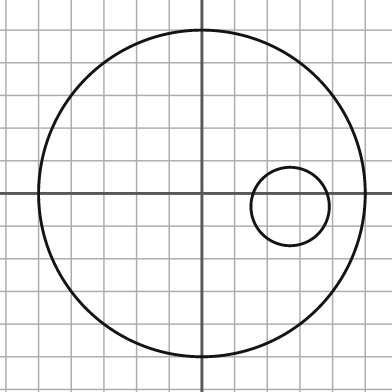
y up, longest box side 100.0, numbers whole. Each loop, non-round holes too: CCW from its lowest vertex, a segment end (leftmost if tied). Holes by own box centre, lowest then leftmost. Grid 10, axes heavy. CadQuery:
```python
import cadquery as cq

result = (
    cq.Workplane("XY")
    .moveTo(0.0, 0.0)
    .circle(50.0)
    .moveTo(27.0, -4.0)
    .circle(12.0)
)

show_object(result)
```